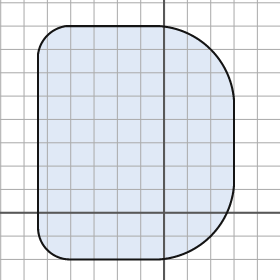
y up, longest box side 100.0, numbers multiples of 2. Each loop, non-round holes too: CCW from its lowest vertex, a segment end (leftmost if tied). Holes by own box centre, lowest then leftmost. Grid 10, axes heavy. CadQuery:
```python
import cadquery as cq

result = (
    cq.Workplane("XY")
    .moveTo(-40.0, -20.0)
    .lineTo(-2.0, -20.0)
    .threePointArc((20.0, -10.0), (30.0, 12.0))
    .lineTo(30.0, 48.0)
    .threePointArc((20.0, 70.0), (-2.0, 80.0))
    .lineTo(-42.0, 80.0)
    .threePointArc((-50.0, 76.0), (-54.0, 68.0))
    .lineTo(-54.0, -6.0)
    .threePointArc((-50.0, -16.0), (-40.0, -20.0))
    .close()
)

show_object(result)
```